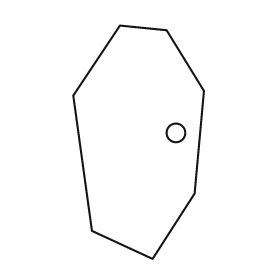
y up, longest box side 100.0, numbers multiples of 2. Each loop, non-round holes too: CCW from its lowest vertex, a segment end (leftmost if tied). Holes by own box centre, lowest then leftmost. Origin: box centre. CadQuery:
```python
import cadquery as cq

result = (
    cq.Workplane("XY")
    .moveTo(6.0, -50.0)
    .lineTo(24.0, -22.0)
    .lineTo(28.0, 22.0)
    .lineTo(12.0, 48.0)
    .lineTo(-8.0, 50.0)
    .lineTo(-28.0, 20.0)
    .lineTo(-20.0, -38.0)
    .close()
    .moveTo(16.0, 4.0)
    .circle(4.0)
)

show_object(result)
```